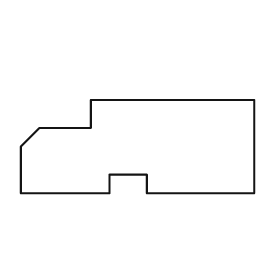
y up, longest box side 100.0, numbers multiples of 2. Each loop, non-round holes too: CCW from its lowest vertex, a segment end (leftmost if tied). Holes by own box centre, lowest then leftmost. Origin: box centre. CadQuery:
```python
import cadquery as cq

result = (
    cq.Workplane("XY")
    .moveTo(-50.0, -20.0)
    .lineTo(-12.0, -20.0)
    .lineTo(-12.0, -12.0)
    .lineTo(4.0, -12.0)
    .lineTo(4.0, -20.0)
    .lineTo(50.0, -20.0)
    .lineTo(50.0, 20.0)
    .lineTo(-20.0, 20.0)
    .lineTo(-20.0, 8.0)
    .lineTo(-42.0, 8.0)
    .lineTo(-50.0, 0.0)
    .close()
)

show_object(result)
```